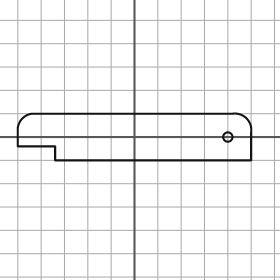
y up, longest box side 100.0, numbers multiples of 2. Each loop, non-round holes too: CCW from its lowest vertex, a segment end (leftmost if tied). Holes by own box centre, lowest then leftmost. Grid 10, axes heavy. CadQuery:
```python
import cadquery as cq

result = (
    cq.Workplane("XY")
    .moveTo(-34.0, -10.0)
    .lineTo(50.0, -10.0)
    .lineTo(50.0, 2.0)
    .threePointArc((48.0, 8.0), (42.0, 10.0))
    .lineTo(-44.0, 10.0)
    .threePointArc((-48.0, 8.0), (-50.0, 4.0))
    .lineTo(-50.0, -4.0)
    .lineTo(-34.0, -4.0)
    .close()
    .moveTo(40.0, 0.0)
    .circle(2.0)
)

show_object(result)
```